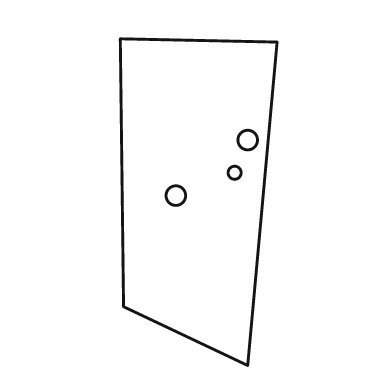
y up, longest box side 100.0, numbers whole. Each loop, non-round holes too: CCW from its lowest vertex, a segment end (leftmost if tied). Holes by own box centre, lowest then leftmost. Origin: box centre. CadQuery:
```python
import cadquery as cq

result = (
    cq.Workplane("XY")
    .moveTo(15.0, -50.0)
    .lineTo(24.0, 49.0)
    .lineTo(-24.0, 50.0)
    .lineTo(-23.0, -32.0)
    .close()
    .moveTo(-7.0, 2.0)
    .circle(3.0)
    .moveTo(11.0, 9.0)
    .circle(2.0)
    .moveTo(15.0, 19.0)
    .circle(3.0)
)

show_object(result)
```